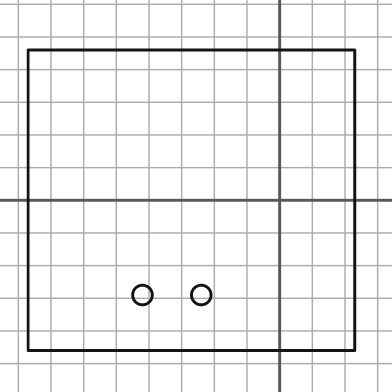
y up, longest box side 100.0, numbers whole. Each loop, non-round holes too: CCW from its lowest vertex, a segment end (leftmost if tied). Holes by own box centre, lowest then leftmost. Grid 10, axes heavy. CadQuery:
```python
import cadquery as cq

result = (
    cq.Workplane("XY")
    .moveTo(-77.0, -46.0)
    .lineTo(23.0, -46.0)
    .lineTo(23.0, 46.0)
    .lineTo(-77.0, 46.0)
    .close()
    .moveTo(-42.0, -29.0)
    .circle(3.0)
    .moveTo(-24.0, -29.0)
    .circle(3.0)
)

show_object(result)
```